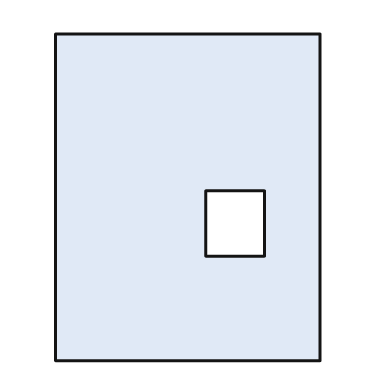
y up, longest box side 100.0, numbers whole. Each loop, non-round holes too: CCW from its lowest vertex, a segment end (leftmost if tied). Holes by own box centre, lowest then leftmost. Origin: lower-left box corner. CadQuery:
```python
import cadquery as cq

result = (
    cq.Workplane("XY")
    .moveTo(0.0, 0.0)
    .lineTo(81.0, 0.0)
    .lineTo(81.0, 100.0)
    .lineTo(0.0, 100.0)
    .close()
    .moveTo(46.0, 32.0)
    .lineTo(64.0, 32.0)
    .lineTo(64.0, 52.0)
    .lineTo(46.0, 52.0)
    .close()
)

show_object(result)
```